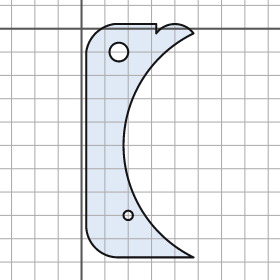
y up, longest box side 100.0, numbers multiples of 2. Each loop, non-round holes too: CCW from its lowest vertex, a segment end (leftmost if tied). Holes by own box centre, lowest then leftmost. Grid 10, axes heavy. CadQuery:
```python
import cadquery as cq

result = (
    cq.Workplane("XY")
    .moveTo(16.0, -98.0)
    .lineTo(48.0, -98.0)
    .threePointArc((18.0, -50.0), (48.0, -2.0))
    .threePointArc((40.0, 2.0), (32.0, -2.0))
    .lineTo(32.0, 2.0)
    .lineTo(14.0, 2.0)
    .threePointArc((6.0, -2.0), (2.0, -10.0))
    .lineTo(2.0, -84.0)
    .threePointArc((6.0, -94.0), (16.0, -98.0))
    .close()
    .moveTo(20.0, -80.0)
    .circle(2.0)
    .moveTo(16.0, -10.0)
    .circle(4.0)
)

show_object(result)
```